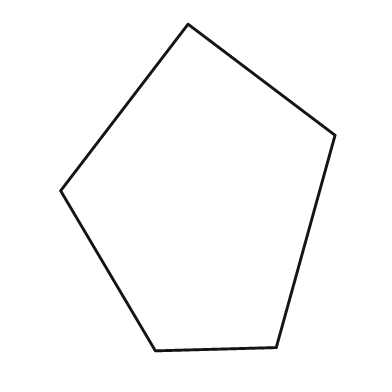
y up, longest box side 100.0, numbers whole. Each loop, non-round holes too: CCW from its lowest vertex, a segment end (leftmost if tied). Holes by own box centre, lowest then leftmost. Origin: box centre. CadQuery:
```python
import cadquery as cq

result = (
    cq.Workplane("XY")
    .moveTo(-13.0, -50.0)
    .lineTo(24.0, -49.0)
    .lineTo(42.0, 16.0)
    .lineTo(-3.0, 50.0)
    .lineTo(-42.0, -1.0)
    .close()
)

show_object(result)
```